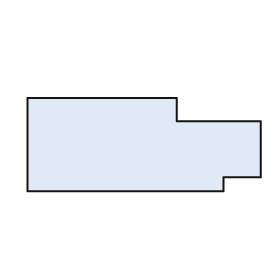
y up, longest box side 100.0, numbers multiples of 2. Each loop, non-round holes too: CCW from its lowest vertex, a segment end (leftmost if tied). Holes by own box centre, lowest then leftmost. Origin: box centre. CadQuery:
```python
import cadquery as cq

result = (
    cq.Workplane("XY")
    .moveTo(-50.0, -20.0)
    .lineTo(34.0, -20.0)
    .lineTo(34.0, -14.0)
    .lineTo(50.0, -14.0)
    .lineTo(50.0, 10.0)
    .lineTo(14.0, 10.0)
    .lineTo(14.0, 20.0)
    .lineTo(-50.0, 20.0)
    .close()
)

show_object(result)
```